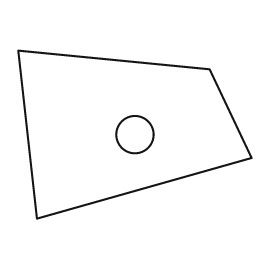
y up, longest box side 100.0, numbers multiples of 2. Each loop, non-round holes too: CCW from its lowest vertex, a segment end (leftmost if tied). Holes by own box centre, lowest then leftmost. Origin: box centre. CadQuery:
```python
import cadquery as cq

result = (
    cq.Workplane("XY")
    .moveTo(-42.0, -36.0)
    .lineTo(50.0, -10.0)
    .lineTo(32.0, 28.0)
    .lineTo(-50.0, 36.0)
    .close()
    .moveTo(0.0, 0.0)
    .circle(8.0)
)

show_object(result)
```